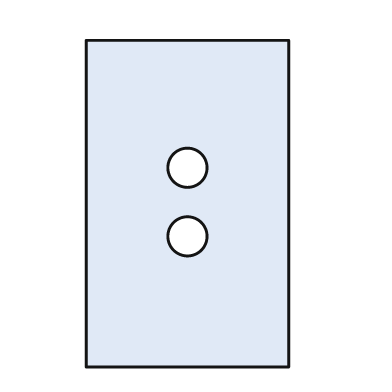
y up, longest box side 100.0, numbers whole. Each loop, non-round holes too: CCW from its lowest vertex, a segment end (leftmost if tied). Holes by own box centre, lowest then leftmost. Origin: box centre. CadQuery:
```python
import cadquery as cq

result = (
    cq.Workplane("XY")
    .moveTo(-31.0, -50.0)
    .lineTo(31.0, -50.0)
    .lineTo(31.0, 50.0)
    .lineTo(-31.0, 50.0)
    .close()
    .moveTo(0.0, -10.0)
    .circle(6.0)
    .moveTo(0.0, 11.0)
    .circle(6.0)
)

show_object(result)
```